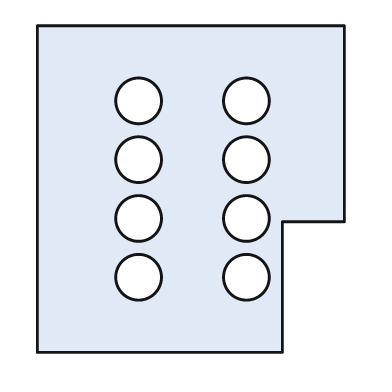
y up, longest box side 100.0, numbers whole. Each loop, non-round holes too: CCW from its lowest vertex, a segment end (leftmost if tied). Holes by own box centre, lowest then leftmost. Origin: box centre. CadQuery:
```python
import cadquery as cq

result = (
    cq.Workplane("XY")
    .moveTo(-47.0, -50.0)
    .lineTo(28.0, -50.0)
    .lineTo(28.0, -10.0)
    .lineTo(47.0, -10.0)
    .lineTo(47.0, 50.0)
    .lineTo(-47.0, 50.0)
    .close()
    .moveTo(-16.0, -27.0)
    .circle(7.0)
    .moveTo(17.0, -27.0)
    .circle(7.0)
    .moveTo(-16.0, -9.0)
    .circle(7.0)
    .moveTo(17.0, -9.0)
    .circle(7.0)
    .moveTo(-16.0, 9.0)
    .circle(7.0)
    .moveTo(17.0, 9.0)
    .circle(7.0)
    .moveTo(-16.0, 27.0)
    .circle(7.0)
    .moveTo(17.0, 27.0)
    .circle(7.0)
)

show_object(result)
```